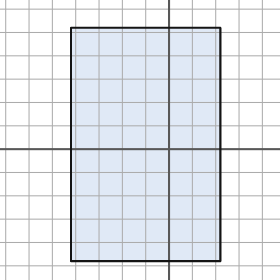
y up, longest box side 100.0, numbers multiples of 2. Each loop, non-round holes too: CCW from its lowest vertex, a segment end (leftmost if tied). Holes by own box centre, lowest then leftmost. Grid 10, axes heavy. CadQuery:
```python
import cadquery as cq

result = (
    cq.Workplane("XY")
    .moveTo(-42.0, -48.0)
    .lineTo(22.0, -48.0)
    .lineTo(22.0, 52.0)
    .lineTo(-42.0, 52.0)
    .close()
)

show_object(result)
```